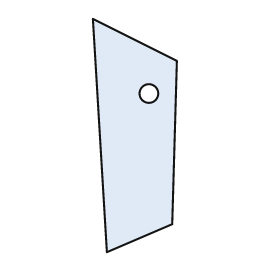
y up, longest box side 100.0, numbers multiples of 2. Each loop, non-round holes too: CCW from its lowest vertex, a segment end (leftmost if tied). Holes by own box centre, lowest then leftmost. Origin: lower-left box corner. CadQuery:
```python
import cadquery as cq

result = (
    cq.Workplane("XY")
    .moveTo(6.0, 0.0)
    .lineTo(34.0, 12.0)
    .lineTo(36.0, 82.0)
    .lineTo(0.0, 100.0)
    .close()
    .moveTo(24.0, 68.0)
    .circle(4.0)
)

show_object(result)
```